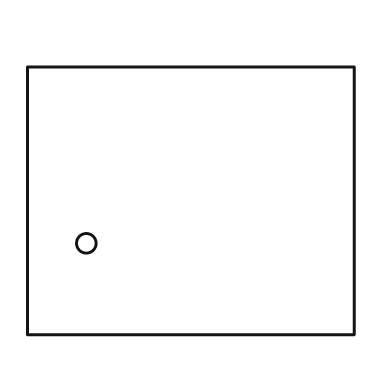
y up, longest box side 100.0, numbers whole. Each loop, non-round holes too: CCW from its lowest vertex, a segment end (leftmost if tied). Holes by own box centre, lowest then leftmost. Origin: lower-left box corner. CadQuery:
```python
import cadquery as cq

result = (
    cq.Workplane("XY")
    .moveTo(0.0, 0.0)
    .lineTo(100.0, 0.0)
    .lineTo(100.0, 82.0)
    .lineTo(0.0, 82.0)
    .close()
    .moveTo(18.0, 28.0)
    .circle(3.0)
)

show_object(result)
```